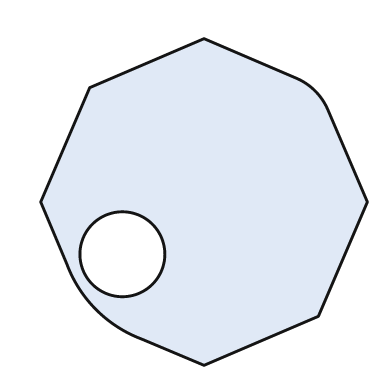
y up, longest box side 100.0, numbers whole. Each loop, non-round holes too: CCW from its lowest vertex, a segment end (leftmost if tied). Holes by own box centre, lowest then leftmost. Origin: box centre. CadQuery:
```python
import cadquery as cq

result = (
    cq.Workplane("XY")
    .moveTo(0.0, -50.0)
    .lineTo(35.0, -35.0)
    .lineTo(50.0, 0.0)
    .lineTo(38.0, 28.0)
    .threePointArc((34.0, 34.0), (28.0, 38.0))
    .lineTo(0.0, 50.0)
    .lineTo(-35.0, 35.0)
    .lineTo(-50.0, 0.0)
    .lineTo(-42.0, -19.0)
    .threePointArc((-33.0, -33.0), (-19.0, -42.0))
    .close()
    .moveTo(-25.0, -16.0)
    .circle(13.0)
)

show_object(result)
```